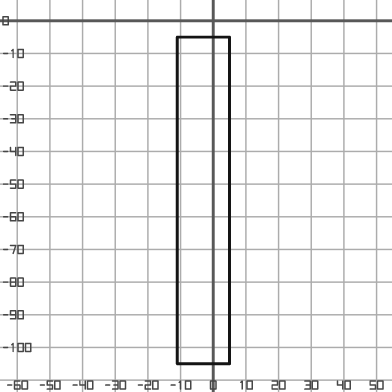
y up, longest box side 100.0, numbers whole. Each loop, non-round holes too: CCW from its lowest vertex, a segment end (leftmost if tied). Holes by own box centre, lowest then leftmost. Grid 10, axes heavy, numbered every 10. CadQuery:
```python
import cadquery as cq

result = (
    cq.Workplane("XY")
    .moveTo(-11.0, -105.0)
    .lineTo(5.0, -105.0)
    .lineTo(5.0, -5.0)
    .lineTo(-11.0, -5.0)
    .close()
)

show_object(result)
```